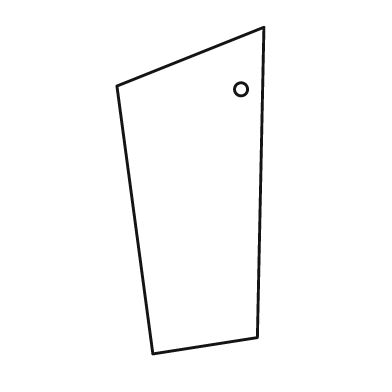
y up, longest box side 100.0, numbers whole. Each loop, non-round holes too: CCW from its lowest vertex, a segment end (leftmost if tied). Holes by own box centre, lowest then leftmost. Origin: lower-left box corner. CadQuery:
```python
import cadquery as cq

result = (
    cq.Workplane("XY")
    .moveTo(11.0, 0.0)
    .lineTo(43.0, 5.0)
    .lineTo(45.0, 100.0)
    .lineTo(0.0, 82.0)
    .close()
    .moveTo(38.0, 81.0)
    .circle(2.0)
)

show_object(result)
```